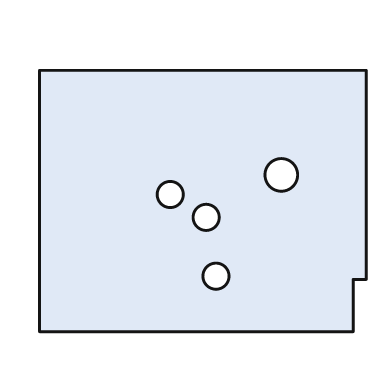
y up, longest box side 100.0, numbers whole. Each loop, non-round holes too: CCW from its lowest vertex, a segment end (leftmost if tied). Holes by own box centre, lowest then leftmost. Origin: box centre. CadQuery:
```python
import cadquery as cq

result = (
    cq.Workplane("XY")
    .moveTo(-50.0, -40.0)
    .lineTo(46.0, -40.0)
    .lineTo(46.0, -24.0)
    .lineTo(50.0, -24.0)
    .lineTo(50.0, 40.0)
    .lineTo(-50.0, 40.0)
    .close()
    .moveTo(4.0, -23.0)
    .circle(4.0)
    .moveTo(1.0, -5.0)
    .circle(4.0)
    .moveTo(-10.0, 2.0)
    .circle(4.0)
    .moveTo(24.0, 8.0)
    .circle(5.0)
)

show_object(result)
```